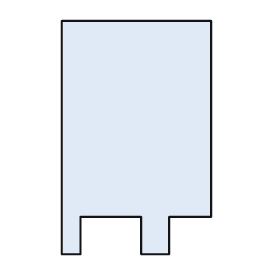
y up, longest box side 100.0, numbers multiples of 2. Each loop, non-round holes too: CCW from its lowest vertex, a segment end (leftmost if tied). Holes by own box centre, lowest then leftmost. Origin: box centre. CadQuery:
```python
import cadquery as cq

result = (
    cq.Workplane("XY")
    .moveTo(-32.0, -50.0)
    .lineTo(-24.0, -50.0)
    .lineTo(-24.0, -34.0)
    .lineTo(2.0, -34.0)
    .lineTo(2.0, -50.0)
    .lineTo(14.0, -50.0)
    .lineTo(14.0, -34.0)
    .lineTo(32.0, -34.0)
    .lineTo(32.0, 50.0)
    .lineTo(-32.0, 50.0)
    .close()
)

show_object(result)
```